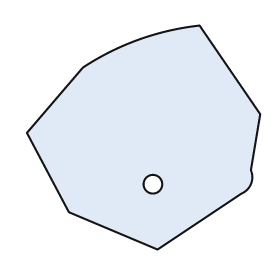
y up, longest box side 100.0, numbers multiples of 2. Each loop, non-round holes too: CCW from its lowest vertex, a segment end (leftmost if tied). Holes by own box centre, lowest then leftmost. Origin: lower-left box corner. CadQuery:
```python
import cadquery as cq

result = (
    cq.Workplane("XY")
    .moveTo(56.0, 0.0)
    .lineTo(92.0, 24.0)
    .threePointArc((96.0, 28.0), (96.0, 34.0))
    .lineTo(100.0, 58.0)
    .lineTo(74.0, 96.0)
    .threePointArc((48.0, 90.0), (24.0, 78.0))
    .lineTo(0.0, 50.0)
    .lineTo(18.0, 16.0)
    .close()
    .moveTo(54.0, 28.0)
    .circle(4.0)
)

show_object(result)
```